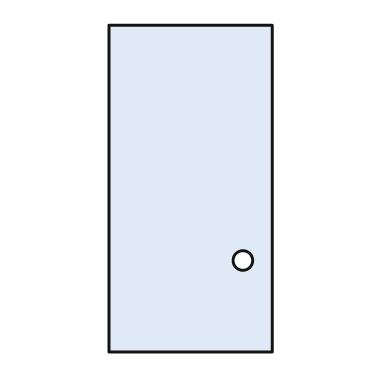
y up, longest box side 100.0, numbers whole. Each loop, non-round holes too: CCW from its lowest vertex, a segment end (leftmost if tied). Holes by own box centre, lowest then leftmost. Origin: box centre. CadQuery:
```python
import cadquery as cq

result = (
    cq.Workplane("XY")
    .moveTo(-25.0, -50.0)
    .lineTo(25.0, -50.0)
    .lineTo(25.0, 50.0)
    .lineTo(-25.0, 50.0)
    .close()
    .moveTo(16.0, -22.0)
    .circle(3.0)
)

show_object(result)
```